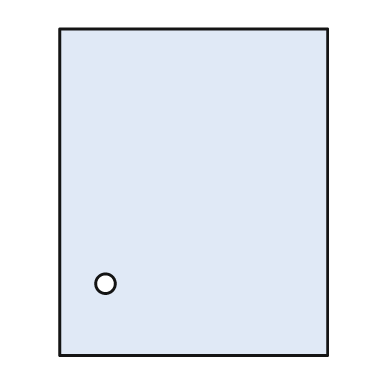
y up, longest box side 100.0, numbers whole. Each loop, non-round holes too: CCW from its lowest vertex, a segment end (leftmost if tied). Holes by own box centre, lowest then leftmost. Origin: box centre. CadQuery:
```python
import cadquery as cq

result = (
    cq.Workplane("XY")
    .moveTo(-41.0, -50.0)
    .lineTo(41.0, -50.0)
    .lineTo(41.0, 50.0)
    .lineTo(-41.0, 50.0)
    .close()
    .moveTo(-27.0, -28.0)
    .circle(3.0)
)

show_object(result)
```